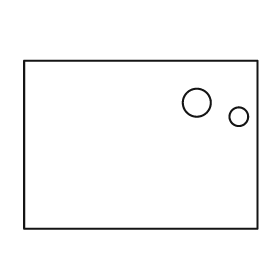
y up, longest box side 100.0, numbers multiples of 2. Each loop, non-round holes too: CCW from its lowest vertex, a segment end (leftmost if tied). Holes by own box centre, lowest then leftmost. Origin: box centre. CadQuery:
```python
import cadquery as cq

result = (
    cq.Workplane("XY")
    .moveTo(-50.0, -36.0)
    .lineTo(50.0, -36.0)
    .lineTo(50.0, 36.0)
    .lineTo(-50.0, 36.0)
    .close()
    .moveTo(42.0, 12.0)
    .circle(4.0)
    .moveTo(24.0, 18.0)
    .circle(6.0)
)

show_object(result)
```